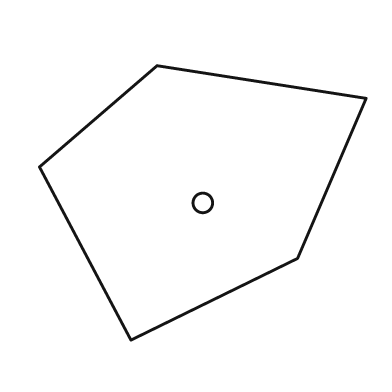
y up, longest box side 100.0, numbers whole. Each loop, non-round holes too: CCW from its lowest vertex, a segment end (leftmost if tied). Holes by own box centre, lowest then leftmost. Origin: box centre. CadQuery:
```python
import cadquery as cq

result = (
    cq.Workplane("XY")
    .moveTo(-22.0, -42.0)
    .lineTo(29.0, -17.0)
    .lineTo(50.0, 32.0)
    .lineTo(-14.0, 42.0)
    .lineTo(-50.0, 11.0)
    .close()
    .moveTo(0.0, 0.0)
    .circle(3.0)
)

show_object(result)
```